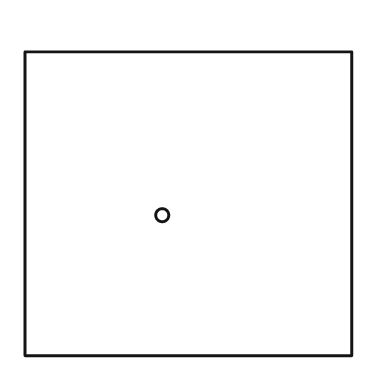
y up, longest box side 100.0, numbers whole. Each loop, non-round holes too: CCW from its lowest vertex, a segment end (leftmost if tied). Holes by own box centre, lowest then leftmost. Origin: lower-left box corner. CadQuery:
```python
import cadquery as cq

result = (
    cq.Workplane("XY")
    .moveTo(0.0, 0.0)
    .lineTo(100.0, 0.0)
    .lineTo(100.0, 93.0)
    .lineTo(0.0, 93.0)
    .close()
    .moveTo(42.0, 43.0)
    .circle(2.0)
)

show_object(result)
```